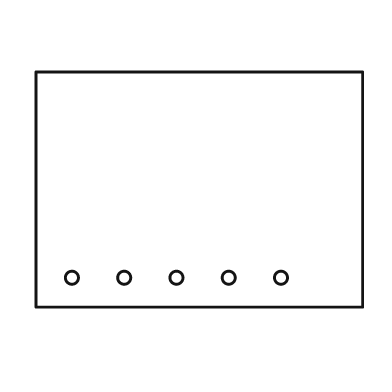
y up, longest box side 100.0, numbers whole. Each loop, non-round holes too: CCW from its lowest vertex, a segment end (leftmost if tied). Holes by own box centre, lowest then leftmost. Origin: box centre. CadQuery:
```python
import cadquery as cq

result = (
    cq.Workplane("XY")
    .moveTo(-50.0, -36.0)
    .lineTo(50.0, -36.0)
    .lineTo(50.0, 36.0)
    .lineTo(-50.0, 36.0)
    .close()
    .moveTo(-39.0, -27.0)
    .circle(2.0)
    .moveTo(-23.0, -27.0)
    .circle(2.0)
    .moveTo(-7.0, -27.0)
    .circle(2.0)
    .moveTo(9.0, -27.0)
    .circle(2.0)
    .moveTo(25.0, -27.0)
    .circle(2.0)
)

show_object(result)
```